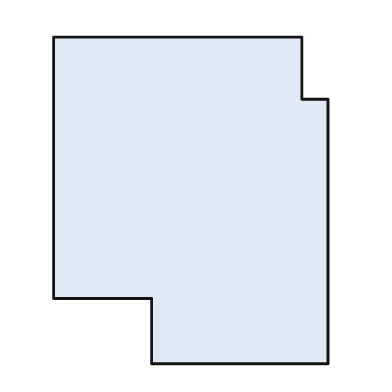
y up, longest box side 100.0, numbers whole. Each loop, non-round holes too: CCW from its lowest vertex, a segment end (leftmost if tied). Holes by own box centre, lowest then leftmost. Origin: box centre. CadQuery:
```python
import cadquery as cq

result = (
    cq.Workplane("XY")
    .moveTo(-12.0, -50.0)
    .lineTo(42.0, -50.0)
    .lineTo(42.0, 31.0)
    .lineTo(34.0, 31.0)
    .lineTo(34.0, 50.0)
    .lineTo(-42.0, 50.0)
    .lineTo(-42.0, -30.0)
    .lineTo(-12.0, -30.0)
    .close()
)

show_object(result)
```